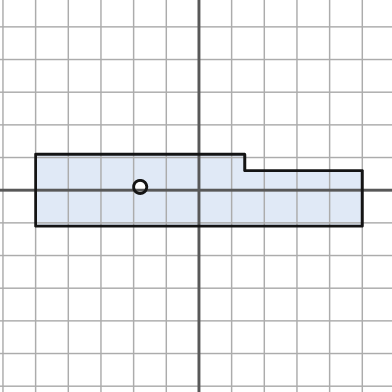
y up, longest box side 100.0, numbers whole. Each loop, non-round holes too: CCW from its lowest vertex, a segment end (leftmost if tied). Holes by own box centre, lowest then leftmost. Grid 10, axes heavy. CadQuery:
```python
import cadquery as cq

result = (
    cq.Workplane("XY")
    .moveTo(-50.0, -11.0)
    .lineTo(50.0, -11.0)
    .lineTo(50.0, 6.0)
    .lineTo(14.0, 6.0)
    .lineTo(14.0, 11.0)
    .lineTo(-50.0, 11.0)
    .close()
    .moveTo(-18.0, 1.0)
    .circle(2.0)
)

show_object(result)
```